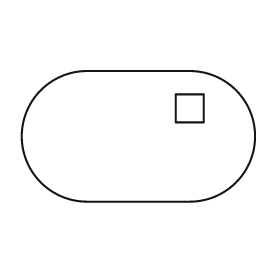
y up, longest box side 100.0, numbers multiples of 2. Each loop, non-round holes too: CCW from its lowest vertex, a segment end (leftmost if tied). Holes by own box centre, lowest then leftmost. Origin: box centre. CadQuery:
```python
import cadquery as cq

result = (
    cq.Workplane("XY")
    .moveTo(-22.0, -28.0)
    .lineTo(22.0, -28.0)
    .threePointArc((50.0, 0.0), (22.0, 28.0))
    .lineTo(-22.0, 28.0)
    .threePointArc((-50.0, 0.0), (-22.0, -28.0))
    .close()
    .moveTo(16.0, 6.0)
    .lineTo(28.0, 6.0)
    .lineTo(28.0, 18.0)
    .lineTo(16.0, 18.0)
    .close()
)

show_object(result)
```